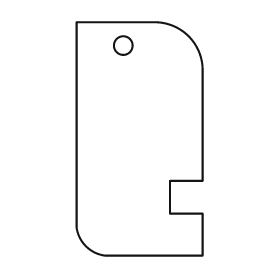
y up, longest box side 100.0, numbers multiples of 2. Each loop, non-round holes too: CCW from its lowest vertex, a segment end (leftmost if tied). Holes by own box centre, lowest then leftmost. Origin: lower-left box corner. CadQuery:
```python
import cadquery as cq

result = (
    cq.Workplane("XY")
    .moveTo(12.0, 0.0)
    .lineTo(54.0, 0.0)
    .lineTo(54.0, 18.0)
    .lineTo(40.0, 18.0)
    .lineTo(40.0, 32.0)
    .lineTo(54.0, 32.0)
    .lineTo(54.0, 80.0)
    .threePointArc((48.0, 94.0), (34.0, 100.0))
    .lineTo(0.0, 100.0)
    .lineTo(0.0, 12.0)
    .threePointArc((4.0, 4.0), (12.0, 0.0))
    .close()
    .moveTo(20.0, 90.0)
    .circle(4.0)
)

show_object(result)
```